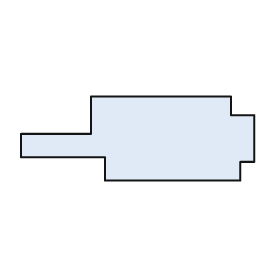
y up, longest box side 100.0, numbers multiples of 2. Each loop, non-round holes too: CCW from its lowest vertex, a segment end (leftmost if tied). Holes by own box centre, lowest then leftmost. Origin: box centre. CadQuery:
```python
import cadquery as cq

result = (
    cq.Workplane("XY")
    .moveTo(-14.0, -18.0)
    .lineTo(44.0, -18.0)
    .lineTo(44.0, -10.0)
    .lineTo(50.0, -10.0)
    .lineTo(50.0, 10.0)
    .lineTo(40.0, 10.0)
    .lineTo(40.0, 18.0)
    .lineTo(-20.0, 18.0)
    .lineTo(-20.0, 2.0)
    .lineTo(-50.0, 2.0)
    .lineTo(-50.0, -8.0)
    .lineTo(-14.0, -8.0)
    .close()
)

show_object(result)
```